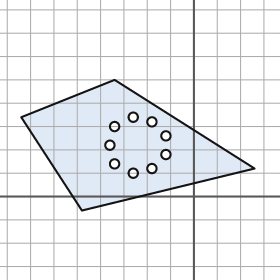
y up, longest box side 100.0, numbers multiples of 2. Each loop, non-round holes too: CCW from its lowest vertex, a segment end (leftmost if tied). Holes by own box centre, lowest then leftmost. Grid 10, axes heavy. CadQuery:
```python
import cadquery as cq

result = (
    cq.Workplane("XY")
    .moveTo(-48.0, -6.0)
    .lineTo(26.0, 12.0)
    .lineTo(-34.0, 50.0)
    .lineTo(-74.0, 34.0)
    .close()
    .moveTo(-26.0, 10.0)
    .circle(2.0)
    .moveTo(-18.0, 12.0)
    .circle(2.0)
    .moveTo(-34.0, 14.0)
    .circle(2.0)
    .moveTo(-12.0, 18.0)
    .circle(2.0)
    .moveTo(-36.0, 22.0)
    .circle(2.0)
    .moveTo(-12.0, 26.0)
    .circle(2.0)
    .moveTo(-34.0, 30.0)
    .circle(2.0)
    .moveTo(-18.0, 32.0)
    .circle(2.0)
    .moveTo(-26.0, 34.0)
    .circle(2.0)
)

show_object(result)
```